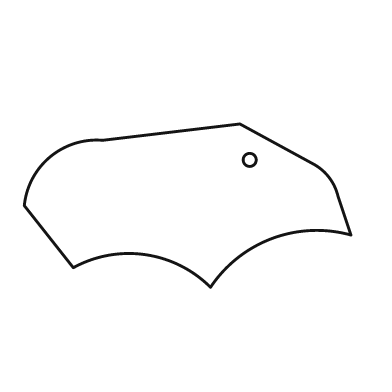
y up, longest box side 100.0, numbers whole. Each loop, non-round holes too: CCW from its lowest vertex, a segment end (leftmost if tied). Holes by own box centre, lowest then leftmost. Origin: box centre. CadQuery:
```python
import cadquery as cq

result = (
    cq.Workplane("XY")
    .moveTo(7.0, -25.0)
    .threePointArc((26.0, -10.0), (50.0, -9.0))
    .lineTo(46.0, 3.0)
    .threePointArc((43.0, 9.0), (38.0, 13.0))
    .lineTo(16.0, 25.0)
    .lineTo(-26.0, 20.0)
    .threePointArc((-42.0, 15.0), (-50.0, 0.0))
    .lineTo(-35.0, -19.0)
    .threePointArc((-13.0, -15.0), (7.0, -25.0))
    .close()
    .moveTo(19.0, 14.0)
    .circle(2.0)
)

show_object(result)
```